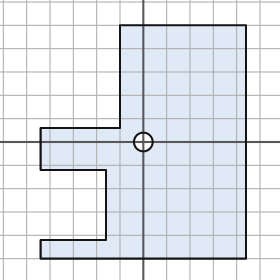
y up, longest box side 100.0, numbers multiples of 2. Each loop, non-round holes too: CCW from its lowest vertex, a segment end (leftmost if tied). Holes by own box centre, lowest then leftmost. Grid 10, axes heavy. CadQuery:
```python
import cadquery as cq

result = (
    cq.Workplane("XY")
    .moveTo(-44.0, -50.0)
    .lineTo(44.0, -50.0)
    .lineTo(44.0, 50.0)
    .lineTo(-10.0, 50.0)
    .lineTo(-10.0, 6.0)
    .lineTo(-44.0, 6.0)
    .lineTo(-44.0, -12.0)
    .lineTo(-16.0, -12.0)
    .lineTo(-16.0, -42.0)
    .lineTo(-44.0, -42.0)
    .close()
    .moveTo(0.0, 0.0)
    .circle(4.0)
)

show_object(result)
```